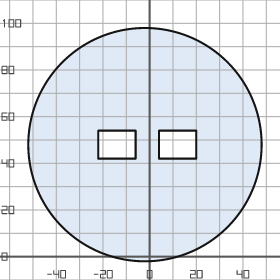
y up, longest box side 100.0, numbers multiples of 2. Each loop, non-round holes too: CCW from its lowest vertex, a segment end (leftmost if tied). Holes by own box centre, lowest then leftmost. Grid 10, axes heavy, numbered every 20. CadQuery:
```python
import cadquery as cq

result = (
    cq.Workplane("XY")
    .moveTo(-2.0, 48.0)
    .circle(50.0)
    .moveTo(-22.0, 42.0)
    .lineTo(-6.0, 42.0)
    .lineTo(-6.0, 54.0)
    .lineTo(-22.0, 54.0)
    .close()
    .moveTo(4.0, 42.0)
    .lineTo(20.0, 42.0)
    .lineTo(20.0, 54.0)
    .lineTo(4.0, 54.0)
    .close()
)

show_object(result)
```